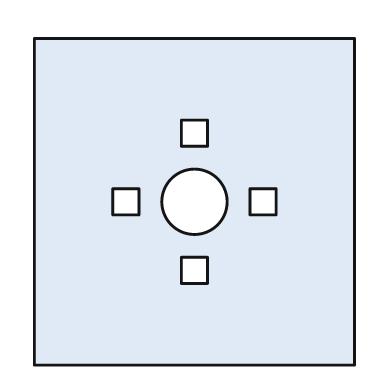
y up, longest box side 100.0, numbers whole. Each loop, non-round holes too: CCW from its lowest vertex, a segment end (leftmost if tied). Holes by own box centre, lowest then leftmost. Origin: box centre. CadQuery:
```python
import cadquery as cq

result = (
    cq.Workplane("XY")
    .moveTo(-49.0, -50.0)
    .lineTo(49.0, -50.0)
    .lineTo(49.0, 50.0)
    .lineTo(-49.0, 50.0)
    .close()
    .moveTo(-4.0, -25.0)
    .lineTo(4.0, -25.0)
    .lineTo(4.0, -17.0)
    .lineTo(-4.0, -17.0)
    .close()
    .moveTo(-25.0, -4.0)
    .lineTo(-17.0, -4.0)
    .lineTo(-17.0, 4.0)
    .lineTo(-25.0, 4.0)
    .close()
    .moveTo(0.0, 0.0)
    .circle(10.0)
    .moveTo(17.0, -4.0)
    .lineTo(25.0, -4.0)
    .lineTo(25.0, 4.0)
    .lineTo(17.0, 4.0)
    .close()
    .moveTo(-4.0, 17.0)
    .lineTo(4.0, 17.0)
    .lineTo(4.0, 25.0)
    .lineTo(-4.0, 25.0)
    .close()
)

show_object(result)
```